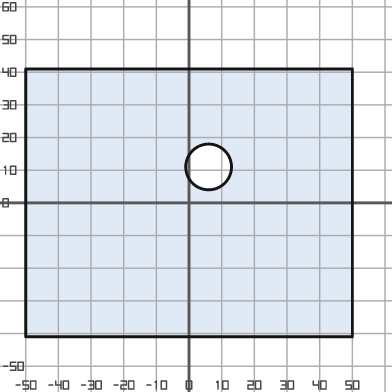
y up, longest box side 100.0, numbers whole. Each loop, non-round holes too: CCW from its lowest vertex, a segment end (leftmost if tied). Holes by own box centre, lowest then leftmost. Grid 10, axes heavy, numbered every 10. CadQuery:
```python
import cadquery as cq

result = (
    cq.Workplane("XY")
    .moveTo(-50.0, -41.0)
    .lineTo(50.0, -41.0)
    .lineTo(50.0, 41.0)
    .lineTo(-50.0, 41.0)
    .close()
    .moveTo(6.0, 11.0)
    .circle(7.0)
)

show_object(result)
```